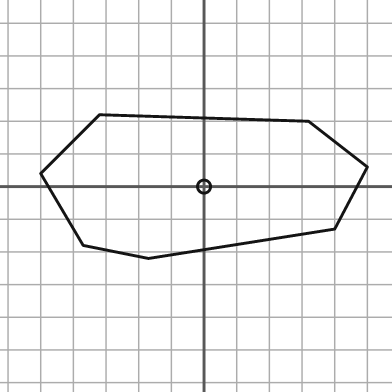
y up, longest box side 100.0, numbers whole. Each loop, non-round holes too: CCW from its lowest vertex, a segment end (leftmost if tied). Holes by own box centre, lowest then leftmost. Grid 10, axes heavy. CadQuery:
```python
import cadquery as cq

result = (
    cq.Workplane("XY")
    .moveTo(-17.0, -22.0)
    .lineTo(40.0, -13.0)
    .lineTo(50.0, 6.0)
    .lineTo(32.0, 20.0)
    .lineTo(-32.0, 22.0)
    .lineTo(-50.0, 4.0)
    .lineTo(-37.0, -18.0)
    .close()
    .moveTo(0.0, 0.0)
    .circle(2.0)
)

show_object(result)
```